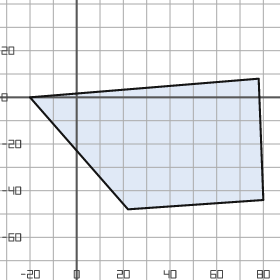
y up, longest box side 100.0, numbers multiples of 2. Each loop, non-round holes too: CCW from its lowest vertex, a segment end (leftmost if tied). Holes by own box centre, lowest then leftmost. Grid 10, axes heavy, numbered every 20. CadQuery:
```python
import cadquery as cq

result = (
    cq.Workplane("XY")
    .moveTo(22.0, -48.0)
    .lineTo(80.0, -44.0)
    .lineTo(78.0, 8.0)
    .lineTo(-20.0, 0.0)
    .close()
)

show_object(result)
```